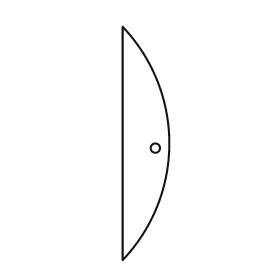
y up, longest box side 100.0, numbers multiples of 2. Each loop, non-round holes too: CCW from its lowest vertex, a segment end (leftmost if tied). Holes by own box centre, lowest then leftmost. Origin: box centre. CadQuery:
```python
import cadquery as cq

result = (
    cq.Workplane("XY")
    .moveTo(-10.0, -50.0)
    .threePointArc((10.0, 0.0), (-10.0, 50.0))
    .close()
    .moveTo(4.0, -2.0)
    .circle(2.0)
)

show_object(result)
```